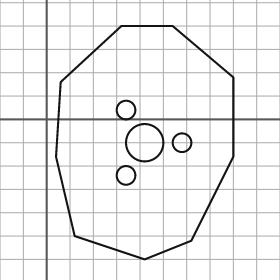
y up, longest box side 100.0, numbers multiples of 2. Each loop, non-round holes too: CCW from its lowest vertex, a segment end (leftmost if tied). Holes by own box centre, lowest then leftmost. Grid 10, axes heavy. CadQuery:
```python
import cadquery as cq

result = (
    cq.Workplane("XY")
    .moveTo(42.0, -60.0)
    .lineTo(62.0, -52.0)
    .lineTo(80.0, -16.0)
    .lineTo(80.0, 18.0)
    .lineTo(54.0, 40.0)
    .lineTo(32.0, 40.0)
    .lineTo(6.0, 16.0)
    .lineTo(4.0, -16.0)
    .lineTo(12.0, -50.0)
    .close()
    .moveTo(34.0, -24.0)
    .circle(4.0)
    .moveTo(42.0, -10.0)
    .circle(8.0)
    .moveTo(58.0, -10.0)
    .circle(4.0)
    .moveTo(34.0, 4.0)
    .circle(4.0)
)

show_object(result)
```